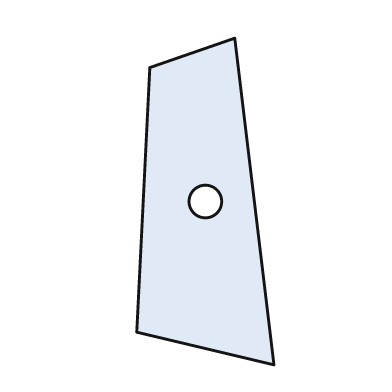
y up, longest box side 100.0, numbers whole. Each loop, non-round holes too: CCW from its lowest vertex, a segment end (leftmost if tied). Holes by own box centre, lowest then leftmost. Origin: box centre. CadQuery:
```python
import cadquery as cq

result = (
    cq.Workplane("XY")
    .moveTo(21.0, -50.0)
    .lineTo(9.0, 50.0)
    .lineTo(-17.0, 41.0)
    .lineTo(-21.0, -40.0)
    .close()
    .moveTo(0.0, 0.0)
    .circle(5.0)
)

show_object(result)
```